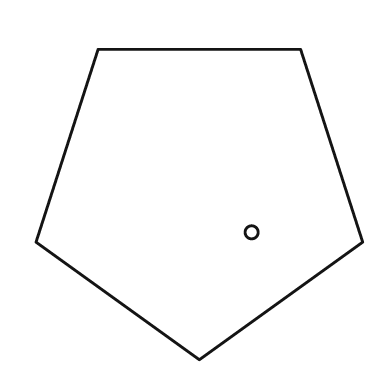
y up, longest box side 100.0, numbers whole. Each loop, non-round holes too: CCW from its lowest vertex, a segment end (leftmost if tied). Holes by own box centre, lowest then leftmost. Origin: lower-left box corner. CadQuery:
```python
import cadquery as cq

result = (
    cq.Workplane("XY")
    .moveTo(50.0, 0.0)
    .lineTo(100.0, 36.0)
    .lineTo(81.0, 95.0)
    .lineTo(19.0, 95.0)
    .lineTo(0.0, 36.0)
    .close()
    .moveTo(66.0, 39.0)
    .circle(2.0)
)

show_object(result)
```